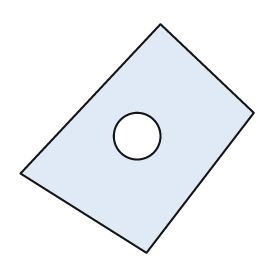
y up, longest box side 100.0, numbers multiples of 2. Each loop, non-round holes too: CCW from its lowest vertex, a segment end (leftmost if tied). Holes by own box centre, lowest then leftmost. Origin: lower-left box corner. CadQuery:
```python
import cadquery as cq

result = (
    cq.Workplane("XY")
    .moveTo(54.0, 0.0)
    .lineTo(100.0, 60.0)
    .lineTo(60.0, 98.0)
    .lineTo(0.0, 34.0)
    .close()
    .moveTo(50.0, 50.0)
    .circle(10.0)
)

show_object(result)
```